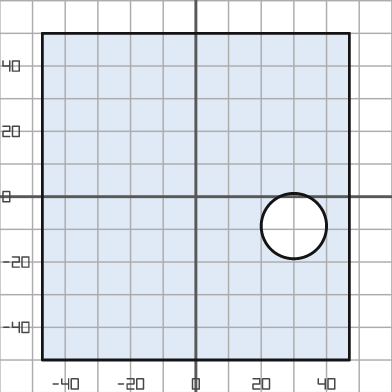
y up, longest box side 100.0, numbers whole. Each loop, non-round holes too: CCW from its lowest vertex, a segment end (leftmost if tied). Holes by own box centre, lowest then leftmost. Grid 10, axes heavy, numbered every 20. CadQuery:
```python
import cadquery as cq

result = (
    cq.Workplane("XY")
    .moveTo(-47.0, -50.0)
    .lineTo(47.0, -50.0)
    .lineTo(47.0, 50.0)
    .lineTo(-47.0, 50.0)
    .close()
    .moveTo(30.0, -9.0)
    .circle(10.0)
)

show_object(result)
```